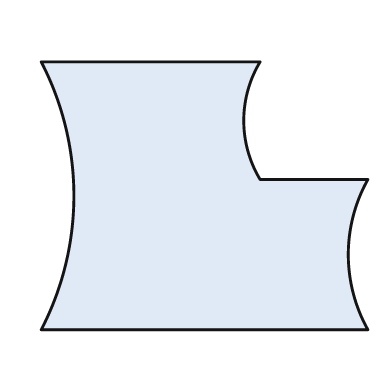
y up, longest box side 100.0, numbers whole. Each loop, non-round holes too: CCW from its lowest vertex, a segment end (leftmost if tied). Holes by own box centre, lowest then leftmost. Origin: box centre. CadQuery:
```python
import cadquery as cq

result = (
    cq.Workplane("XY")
    .moveTo(-50.0, -41.0)
    .lineTo(50.0, -41.0)
    .threePointArc((44.0, -18.0), (50.0, 5.0))
    .lineTo(17.0, 5.0)
    .threePointArc((12.0, 23.0), (17.0, 41.0))
    .lineTo(-50.0, 41.0)
    .threePointArc((-40.0, 0.0), (-50.0, -41.0))
    .close()
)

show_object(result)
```